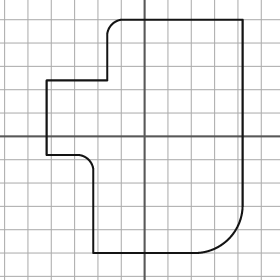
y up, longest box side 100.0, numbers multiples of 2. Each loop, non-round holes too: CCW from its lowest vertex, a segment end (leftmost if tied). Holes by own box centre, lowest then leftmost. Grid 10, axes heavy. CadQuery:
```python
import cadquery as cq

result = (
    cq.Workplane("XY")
    .moveTo(-22.0, -50.0)
    .lineTo(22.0, -50.0)
    .threePointArc((36.0, -44.0), (42.0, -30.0))
    .lineTo(42.0, 50.0)
    .lineTo(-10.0, 50.0)
    .threePointArc((-14.0, 48.0), (-16.0, 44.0))
    .lineTo(-16.0, 24.0)
    .lineTo(-42.0, 24.0)
    .lineTo(-42.0, -8.0)
    .lineTo(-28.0, -8.0)
    .threePointArc((-24.0, -10.0), (-22.0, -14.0))
    .close()
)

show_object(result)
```